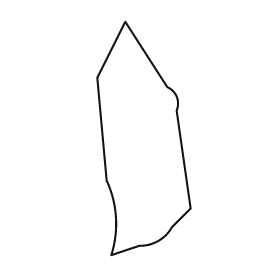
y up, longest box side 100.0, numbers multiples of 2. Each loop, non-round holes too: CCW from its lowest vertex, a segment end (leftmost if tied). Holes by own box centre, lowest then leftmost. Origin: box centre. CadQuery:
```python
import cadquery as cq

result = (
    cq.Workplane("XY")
    .moveTo(-14.0, -50.0)
    .lineTo(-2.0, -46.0)
    .threePointArc((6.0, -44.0), (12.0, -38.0))
    .lineTo(20.0, -30.0)
    .lineTo(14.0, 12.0)
    .threePointArc((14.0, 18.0), (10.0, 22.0))
    .lineTo(-8.0, 50.0)
    .lineTo(-20.0, 26.0)
    .lineTo(-16.0, -18.0)
    .threePointArc((-12.0, -34.0), (-14.0, -50.0))
    .close()
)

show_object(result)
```